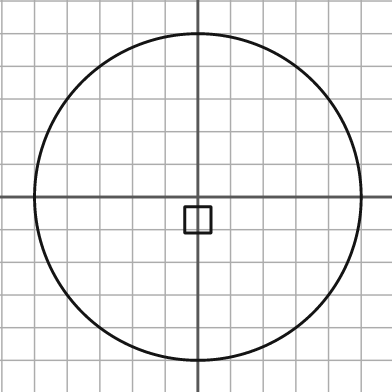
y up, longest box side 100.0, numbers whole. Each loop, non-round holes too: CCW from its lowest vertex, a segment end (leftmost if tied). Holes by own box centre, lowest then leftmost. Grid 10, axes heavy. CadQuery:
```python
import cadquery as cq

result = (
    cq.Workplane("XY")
    .moveTo(0.0, 0.0)
    .circle(50.0)
    .moveTo(-4.0, -11.0)
    .lineTo(4.0, -11.0)
    .lineTo(4.0, -3.0)
    .lineTo(-4.0, -3.0)
    .close()
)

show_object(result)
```